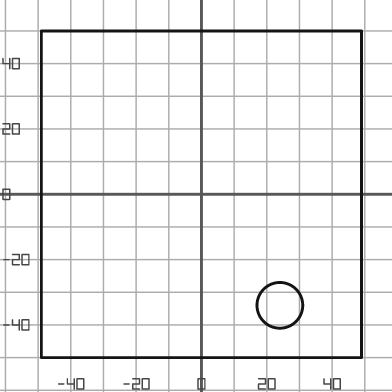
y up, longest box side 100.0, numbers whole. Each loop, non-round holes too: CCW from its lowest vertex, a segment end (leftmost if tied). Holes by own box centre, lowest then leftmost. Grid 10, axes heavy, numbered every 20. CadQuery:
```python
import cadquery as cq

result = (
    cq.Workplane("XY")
    .moveTo(-49.0, -50.0)
    .lineTo(49.0, -50.0)
    .lineTo(49.0, 50.0)
    .lineTo(-49.0, 50.0)
    .close()
    .moveTo(24.0, -34.0)
    .circle(7.0)
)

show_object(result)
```